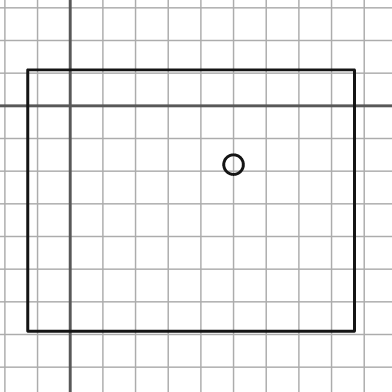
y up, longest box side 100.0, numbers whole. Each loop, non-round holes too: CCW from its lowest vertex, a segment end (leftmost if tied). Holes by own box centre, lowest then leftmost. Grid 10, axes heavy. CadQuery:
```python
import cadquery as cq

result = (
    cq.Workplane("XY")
    .moveTo(-13.0, -69.0)
    .lineTo(87.0, -69.0)
    .lineTo(87.0, 11.0)
    .lineTo(-13.0, 11.0)
    .close()
    .moveTo(50.0, -18.0)
    .circle(3.0)
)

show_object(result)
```